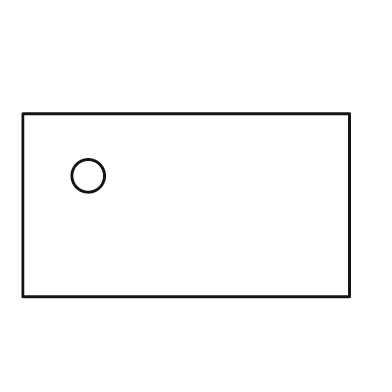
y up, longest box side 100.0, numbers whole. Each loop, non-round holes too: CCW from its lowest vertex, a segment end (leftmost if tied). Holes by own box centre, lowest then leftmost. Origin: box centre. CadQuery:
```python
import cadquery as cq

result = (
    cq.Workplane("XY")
    .moveTo(-50.0, -28.0)
    .lineTo(50.0, -28.0)
    .lineTo(50.0, 28.0)
    .lineTo(-50.0, 28.0)
    .close()
    .moveTo(-30.0, 9.0)
    .circle(5.0)
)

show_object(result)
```